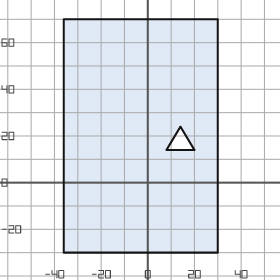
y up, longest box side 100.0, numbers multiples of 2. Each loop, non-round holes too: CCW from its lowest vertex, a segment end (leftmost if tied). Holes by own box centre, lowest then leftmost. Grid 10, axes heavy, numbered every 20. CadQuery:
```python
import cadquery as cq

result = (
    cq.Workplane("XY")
    .moveTo(-36.0, -30.0)
    .lineTo(30.0, -30.0)
    .lineTo(30.0, 70.0)
    .lineTo(-36.0, 70.0)
    .close()
    .moveTo(8.0, 14.0)
    .lineTo(20.0, 14.0)
    .lineTo(14.0, 24.0)
    .close()
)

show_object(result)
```